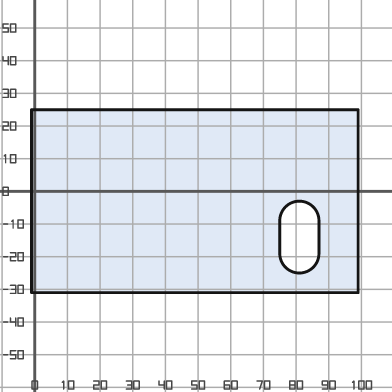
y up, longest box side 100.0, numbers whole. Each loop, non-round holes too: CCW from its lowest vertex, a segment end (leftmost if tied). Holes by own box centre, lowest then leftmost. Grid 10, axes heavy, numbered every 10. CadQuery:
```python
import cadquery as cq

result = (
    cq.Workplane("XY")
    .moveTo(-1.0, -31.0)
    .lineTo(99.0, -31.0)
    .lineTo(99.0, 25.0)
    .lineTo(-1.0, 25.0)
    .close()
    .moveTo(75.0, -19.0)
    .threePointArc((81.0, -25.0), (87.0, -19.0))
    .lineTo(87.0, -9.0)
    .threePointArc((81.0, -3.0), (75.0, -9.0))
    .close()
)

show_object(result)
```